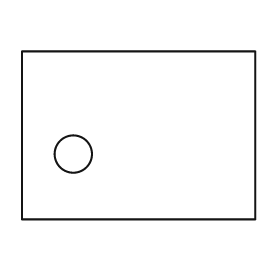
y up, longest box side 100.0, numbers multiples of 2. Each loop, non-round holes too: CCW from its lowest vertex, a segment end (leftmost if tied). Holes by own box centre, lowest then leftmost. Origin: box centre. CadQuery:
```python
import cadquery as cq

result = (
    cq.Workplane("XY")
    .moveTo(-50.0, -36.0)
    .lineTo(50.0, -36.0)
    .lineTo(50.0, 36.0)
    .lineTo(-50.0, 36.0)
    .close()
    .moveTo(-28.0, -8.0)
    .circle(8.0)
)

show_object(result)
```